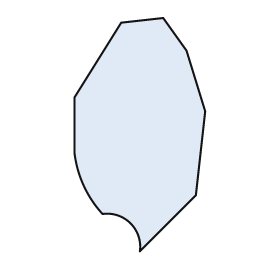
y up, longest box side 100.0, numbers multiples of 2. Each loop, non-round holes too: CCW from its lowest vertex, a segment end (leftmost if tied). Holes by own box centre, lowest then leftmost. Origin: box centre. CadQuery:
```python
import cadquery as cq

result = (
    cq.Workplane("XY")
    .moveTo(0.0, -50.0)
    .lineTo(24.0, -26.0)
    .lineTo(28.0, 10.0)
    .lineTo(20.0, 36.0)
    .lineTo(10.0, 50.0)
    .lineTo(-8.0, 48.0)
    .lineTo(-28.0, 16.0)
    .lineTo(-28.0, -8.0)
    .threePointArc((-24.0, -22.0), (-16.0, -34.0))
    .threePointArc((-4.0, -38.0), (0.0, -50.0))
    .close()
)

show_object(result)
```